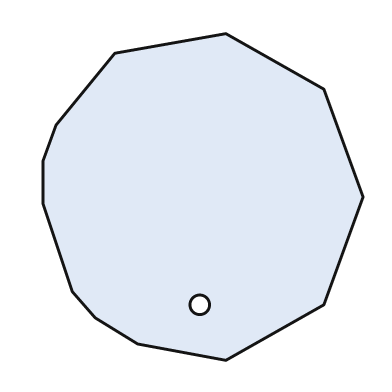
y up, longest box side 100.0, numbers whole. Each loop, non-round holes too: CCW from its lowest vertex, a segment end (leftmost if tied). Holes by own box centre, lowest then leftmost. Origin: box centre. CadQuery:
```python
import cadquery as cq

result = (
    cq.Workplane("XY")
    .moveTo(7.0, -50.0)
    .lineTo(37.0, -33.0)
    .lineTo(49.0, 0.0)
    .lineTo(37.0, 33.0)
    .lineTo(7.0, 50.0)
    .lineTo(-27.0, 44.0)
    .lineTo(-45.0, 22.0)
    .lineTo(-49.0, 11.0)
    .lineTo(-49.0, -2.0)
    .lineTo(-40.0, -29.0)
    .lineTo(-33.0, -37.0)
    .lineTo(-20.0, -45.0)
    .close()
    .moveTo(-1.0, -33.0)
    .circle(3.0)
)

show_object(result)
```